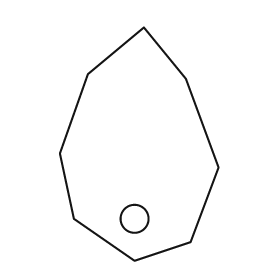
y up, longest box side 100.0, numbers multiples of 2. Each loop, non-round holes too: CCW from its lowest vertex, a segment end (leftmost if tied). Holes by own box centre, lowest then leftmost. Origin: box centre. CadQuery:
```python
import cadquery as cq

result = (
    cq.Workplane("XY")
    .moveTo(-2.0, -50.0)
    .lineTo(22.0, -42.0)
    .lineTo(34.0, -10.0)
    .lineTo(20.0, 28.0)
    .lineTo(2.0, 50.0)
    .lineTo(-22.0, 30.0)
    .lineTo(-34.0, -4.0)
    .lineTo(-28.0, -32.0)
    .close()
    .moveTo(-2.0, -32.0)
    .circle(6.0)
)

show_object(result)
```